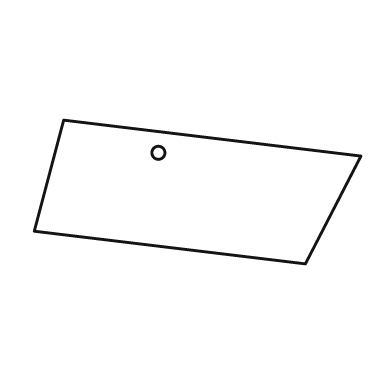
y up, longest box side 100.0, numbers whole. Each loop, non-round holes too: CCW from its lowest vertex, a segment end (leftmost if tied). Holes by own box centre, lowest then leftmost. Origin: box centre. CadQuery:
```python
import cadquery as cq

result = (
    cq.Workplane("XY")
    .moveTo(33.0, -22.0)
    .lineTo(50.0, 11.0)
    .lineTo(-41.0, 22.0)
    .lineTo(-50.0, -12.0)
    .close()
    .moveTo(-12.0, 12.0)
    .circle(2.0)
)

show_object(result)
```